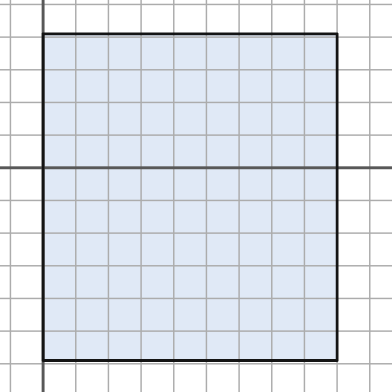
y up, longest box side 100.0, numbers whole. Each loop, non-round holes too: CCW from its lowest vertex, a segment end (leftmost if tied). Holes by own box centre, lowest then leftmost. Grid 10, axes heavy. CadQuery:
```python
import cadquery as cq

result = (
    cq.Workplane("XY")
    .moveTo(0.0, -59.0)
    .lineTo(90.0, -59.0)
    .lineTo(90.0, 41.0)
    .lineTo(0.0, 41.0)
    .close()
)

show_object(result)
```